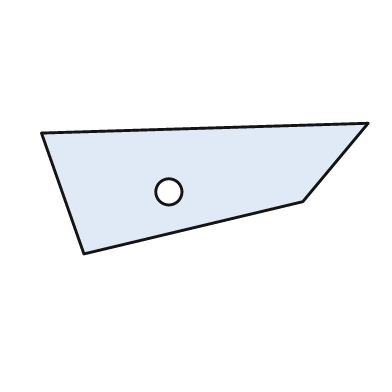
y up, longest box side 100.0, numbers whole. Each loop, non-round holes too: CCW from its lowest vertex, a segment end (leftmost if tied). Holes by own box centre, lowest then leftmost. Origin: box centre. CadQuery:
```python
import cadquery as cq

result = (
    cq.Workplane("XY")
    .moveTo(-37.0, -20.0)
    .lineTo(30.0, -4.0)
    .lineTo(50.0, 20.0)
    .lineTo(-50.0, 17.0)
    .close()
    .moveTo(-11.0, -1.0)
    .circle(4.0)
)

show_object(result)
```